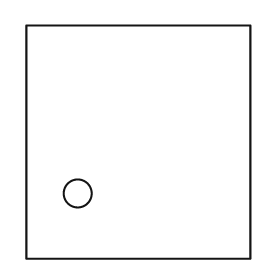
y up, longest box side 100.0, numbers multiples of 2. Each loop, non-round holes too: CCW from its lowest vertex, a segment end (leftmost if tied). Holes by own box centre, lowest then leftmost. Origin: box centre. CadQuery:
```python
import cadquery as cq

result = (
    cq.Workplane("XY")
    .moveTo(-48.0, -50.0)
    .lineTo(48.0, -50.0)
    .lineTo(48.0, 50.0)
    .lineTo(-48.0, 50.0)
    .close()
    .moveTo(-26.0, -22.0)
    .circle(6.0)
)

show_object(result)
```